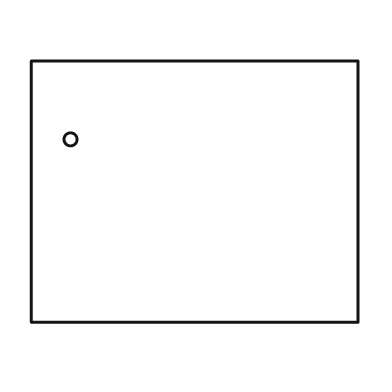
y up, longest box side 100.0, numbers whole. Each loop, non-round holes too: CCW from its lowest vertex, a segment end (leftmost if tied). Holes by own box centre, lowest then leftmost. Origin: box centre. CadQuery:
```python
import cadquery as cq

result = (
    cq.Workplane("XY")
    .moveTo(-50.0, -40.0)
    .lineTo(50.0, -40.0)
    .lineTo(50.0, 40.0)
    .lineTo(-50.0, 40.0)
    .close()
    .moveTo(-38.0, 16.0)
    .circle(2.0)
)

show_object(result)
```